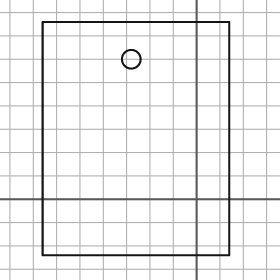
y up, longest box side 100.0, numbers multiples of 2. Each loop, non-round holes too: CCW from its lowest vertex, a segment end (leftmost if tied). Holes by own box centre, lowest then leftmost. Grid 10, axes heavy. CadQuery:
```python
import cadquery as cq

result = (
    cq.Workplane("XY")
    .moveTo(-66.0, -24.0)
    .lineTo(14.0, -24.0)
    .lineTo(14.0, 76.0)
    .lineTo(-66.0, 76.0)
    .close()
    .moveTo(-28.0, 60.0)
    .circle(4.0)
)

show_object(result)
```